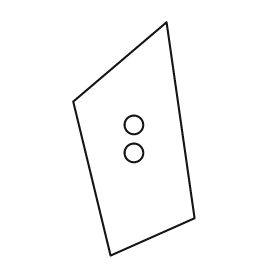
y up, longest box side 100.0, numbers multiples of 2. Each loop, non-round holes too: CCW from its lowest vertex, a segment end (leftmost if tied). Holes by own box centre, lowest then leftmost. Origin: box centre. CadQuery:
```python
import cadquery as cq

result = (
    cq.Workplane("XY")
    .moveTo(-10.0, -50.0)
    .lineTo(26.0, -34.0)
    .lineTo(14.0, 50.0)
    .lineTo(-26.0, 16.0)
    .close()
    .moveTo(0.0, -6.0)
    .circle(4.0)
    .moveTo(0.0, 6.0)
    .circle(4.0)
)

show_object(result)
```